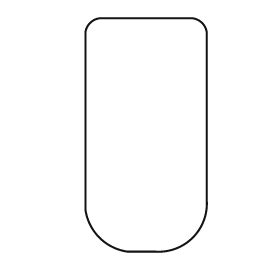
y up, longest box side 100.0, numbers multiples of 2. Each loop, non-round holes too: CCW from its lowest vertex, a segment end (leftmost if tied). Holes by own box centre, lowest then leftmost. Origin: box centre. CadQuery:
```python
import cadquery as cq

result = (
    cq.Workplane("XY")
    .moveTo(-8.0, -50.0)
    .lineTo(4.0, -50.0)
    .threePointArc((20.0, -44.0), (26.0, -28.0))
    .lineTo(26.0, 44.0)
    .threePointArc((24.0, 48.0), (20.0, 50.0))
    .lineTo(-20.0, 50.0)
    .threePointArc((-24.0, 48.0), (-26.0, 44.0))
    .lineTo(-26.0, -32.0)
    .threePointArc((-20.0, -44.0), (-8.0, -50.0))
    .close()
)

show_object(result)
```